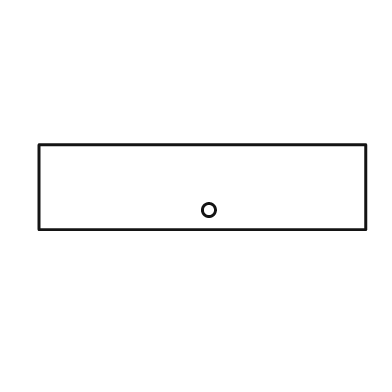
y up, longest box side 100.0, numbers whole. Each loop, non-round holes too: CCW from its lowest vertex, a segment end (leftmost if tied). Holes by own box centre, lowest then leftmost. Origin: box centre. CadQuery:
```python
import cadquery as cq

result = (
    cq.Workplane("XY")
    .moveTo(-50.0, -13.0)
    .lineTo(50.0, -13.0)
    .lineTo(50.0, 13.0)
    .lineTo(-50.0, 13.0)
    .close()
    .moveTo(2.0, -7.0)
    .circle(2.0)
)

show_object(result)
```